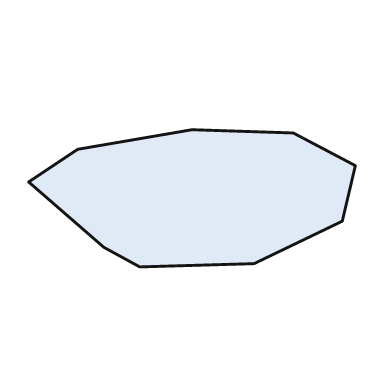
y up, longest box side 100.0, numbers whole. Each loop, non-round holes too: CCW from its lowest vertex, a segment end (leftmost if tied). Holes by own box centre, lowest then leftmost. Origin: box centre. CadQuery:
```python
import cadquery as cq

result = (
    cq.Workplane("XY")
    .moveTo(-16.0, -21.0)
    .lineTo(19.0, -20.0)
    .lineTo(46.0, -7.0)
    .lineTo(50.0, 10.0)
    .lineTo(31.0, 20.0)
    .lineTo(0.0, 21.0)
    .lineTo(-35.0, 15.0)
    .lineTo(-50.0, 5.0)
    .lineTo(-27.0, -15.0)
    .close()
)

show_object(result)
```